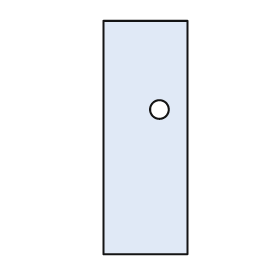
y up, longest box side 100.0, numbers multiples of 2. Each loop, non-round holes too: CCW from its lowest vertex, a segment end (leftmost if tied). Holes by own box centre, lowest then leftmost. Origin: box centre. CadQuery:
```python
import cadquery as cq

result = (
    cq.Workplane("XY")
    .moveTo(-18.0, -50.0)
    .lineTo(18.0, -50.0)
    .lineTo(18.0, 50.0)
    .lineTo(-18.0, 50.0)
    .close()
    .moveTo(6.0, 12.0)
    .circle(4.0)
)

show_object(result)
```